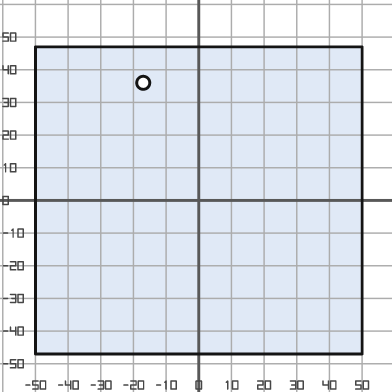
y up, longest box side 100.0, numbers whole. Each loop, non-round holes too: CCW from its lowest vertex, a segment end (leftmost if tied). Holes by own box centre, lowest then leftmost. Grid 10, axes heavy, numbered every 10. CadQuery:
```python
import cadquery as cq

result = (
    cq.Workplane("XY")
    .moveTo(-50.0, -47.0)
    .lineTo(50.0, -47.0)
    .lineTo(50.0, 47.0)
    .lineTo(-50.0, 47.0)
    .close()
    .moveTo(-17.0, 36.0)
    .circle(2.0)
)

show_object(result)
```